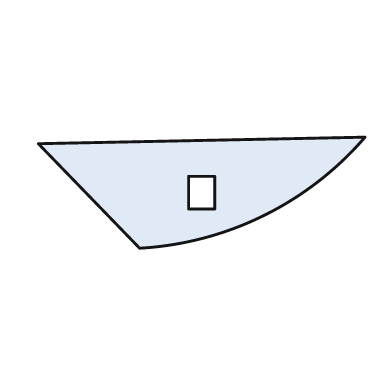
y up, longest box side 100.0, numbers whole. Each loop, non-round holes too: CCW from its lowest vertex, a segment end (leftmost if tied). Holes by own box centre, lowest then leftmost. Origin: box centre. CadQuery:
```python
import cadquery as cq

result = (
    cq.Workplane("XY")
    .moveTo(-19.0, -17.0)
    .threePointArc((19.0, -7.0), (50.0, 17.0))
    .lineTo(-50.0, 15.0)
    .close()
    .moveTo(-4.0, -5.0)
    .lineTo(4.0, -5.0)
    .lineTo(4.0, 5.0)
    .lineTo(-4.0, 5.0)
    .close()
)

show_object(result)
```